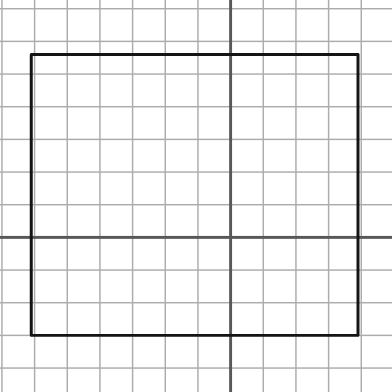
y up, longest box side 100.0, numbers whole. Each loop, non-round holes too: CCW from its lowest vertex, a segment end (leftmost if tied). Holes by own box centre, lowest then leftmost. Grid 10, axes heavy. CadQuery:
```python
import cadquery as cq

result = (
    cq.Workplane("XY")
    .moveTo(-61.0, -30.0)
    .lineTo(39.0, -30.0)
    .lineTo(39.0, 56.0)
    .lineTo(-61.0, 56.0)
    .close()
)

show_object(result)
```